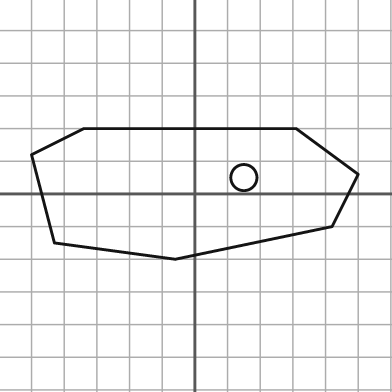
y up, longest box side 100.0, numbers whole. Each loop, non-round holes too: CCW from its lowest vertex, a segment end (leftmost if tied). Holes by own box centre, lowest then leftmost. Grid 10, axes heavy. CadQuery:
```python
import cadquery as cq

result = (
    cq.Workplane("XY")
    .moveTo(-6.0, -20.0)
    .lineTo(42.0, -10.0)
    .lineTo(50.0, 6.0)
    .lineTo(31.0, 20.0)
    .lineTo(-34.0, 20.0)
    .lineTo(-50.0, 12.0)
    .lineTo(-43.0, -15.0)
    .close()
    .moveTo(15.0, 5.0)
    .circle(4.0)
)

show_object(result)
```